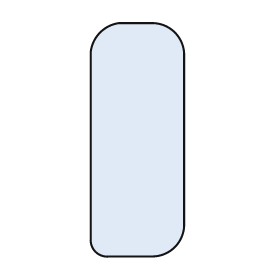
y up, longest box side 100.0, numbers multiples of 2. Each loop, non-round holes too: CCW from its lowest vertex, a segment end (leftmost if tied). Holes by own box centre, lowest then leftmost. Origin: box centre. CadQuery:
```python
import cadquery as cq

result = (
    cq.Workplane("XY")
    .moveTo(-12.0, -50.0)
    .lineTo(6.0, -50.0)
    .threePointArc((16.0, -46.0), (20.0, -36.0))
    .lineTo(20.0, 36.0)
    .threePointArc((16.0, 46.0), (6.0, 50.0))
    .lineTo(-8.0, 50.0)
    .threePointArc((-16.0, 46.0), (-20.0, 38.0))
    .lineTo(-20.0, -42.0)
    .threePointArc((-18.0, -48.0), (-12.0, -50.0))
    .close()
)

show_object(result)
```